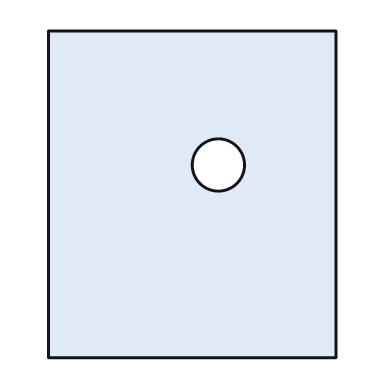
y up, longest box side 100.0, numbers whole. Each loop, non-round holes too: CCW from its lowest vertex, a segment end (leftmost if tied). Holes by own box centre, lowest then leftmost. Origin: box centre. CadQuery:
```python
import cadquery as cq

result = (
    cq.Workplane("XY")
    .moveTo(-44.0, -50.0)
    .lineTo(44.0, -50.0)
    .lineTo(44.0, 50.0)
    .lineTo(-44.0, 50.0)
    .close()
    .moveTo(8.0, 9.0)
    .circle(8.0)
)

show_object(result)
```